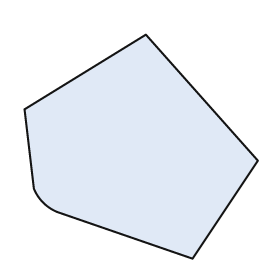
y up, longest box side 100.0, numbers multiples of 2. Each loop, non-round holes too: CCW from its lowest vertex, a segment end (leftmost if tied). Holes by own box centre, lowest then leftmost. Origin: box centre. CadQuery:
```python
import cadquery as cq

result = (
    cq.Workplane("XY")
    .moveTo(22.0, -48.0)
    .lineTo(50.0, -6.0)
    .lineTo(2.0, 48.0)
    .lineTo(-50.0, 16.0)
    .lineTo(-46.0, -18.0)
    .threePointArc((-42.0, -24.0), (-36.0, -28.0))
    .close()
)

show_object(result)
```